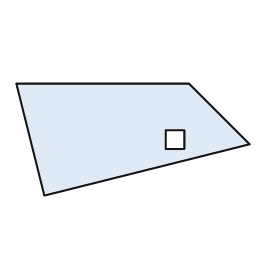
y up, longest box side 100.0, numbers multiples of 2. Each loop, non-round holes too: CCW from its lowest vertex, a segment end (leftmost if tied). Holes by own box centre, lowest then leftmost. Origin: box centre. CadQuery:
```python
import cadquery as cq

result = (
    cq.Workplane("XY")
    .moveTo(-38.0, -24.0)
    .lineTo(50.0, -2.0)
    .lineTo(24.0, 24.0)
    .lineTo(-50.0, 24.0)
    .close()
    .moveTo(14.0, -4.0)
    .lineTo(22.0, -4.0)
    .lineTo(22.0, 4.0)
    .lineTo(14.0, 4.0)
    .close()
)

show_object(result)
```